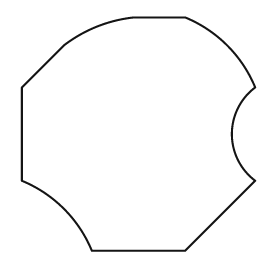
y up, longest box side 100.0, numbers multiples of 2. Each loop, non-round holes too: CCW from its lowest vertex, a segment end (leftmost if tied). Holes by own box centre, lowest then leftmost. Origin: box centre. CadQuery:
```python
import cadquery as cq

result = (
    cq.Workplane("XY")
    .moveTo(-20.0, -50.0)
    .lineTo(20.0, -50.0)
    .lineTo(50.0, -20.0)
    .threePointArc((40.0, 0.0), (50.0, 20.0))
    .threePointArc((38.0, 38.0), (20.0, 50.0))
    .lineTo(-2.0, 50.0)
    .threePointArc((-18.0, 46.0), (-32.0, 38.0))
    .lineTo(-50.0, 20.0)
    .lineTo(-50.0, -20.0)
    .threePointArc((-32.0, -32.0), (-20.0, -50.0))
    .close()
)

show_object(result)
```